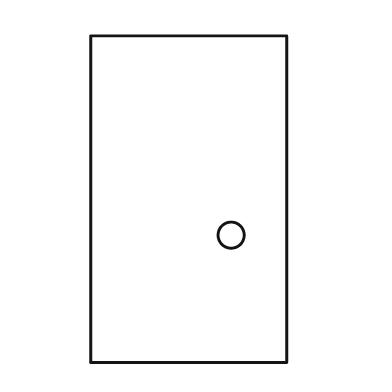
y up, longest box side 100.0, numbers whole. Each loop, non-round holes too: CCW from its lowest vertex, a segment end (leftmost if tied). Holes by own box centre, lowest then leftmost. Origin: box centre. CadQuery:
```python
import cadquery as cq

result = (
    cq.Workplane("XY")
    .moveTo(-30.0, -50.0)
    .lineTo(30.0, -50.0)
    .lineTo(30.0, 50.0)
    .lineTo(-30.0, 50.0)
    .close()
    .moveTo(13.0, -11.0)
    .circle(4.0)
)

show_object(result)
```